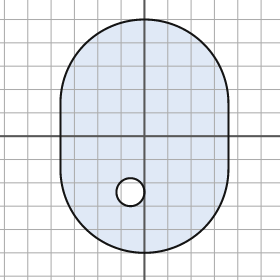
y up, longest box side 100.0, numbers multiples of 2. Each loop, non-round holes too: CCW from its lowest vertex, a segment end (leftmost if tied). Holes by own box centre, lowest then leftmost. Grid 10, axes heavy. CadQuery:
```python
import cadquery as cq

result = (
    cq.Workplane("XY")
    .moveTo(-36.0, -14.0)
    .threePointArc((0.0, -50.0), (36.0, -14.0))
    .lineTo(36.0, 14.0)
    .threePointArc((0.0, 50.0), (-36.0, 14.0))
    .close()
    .moveTo(-6.0, -24.0)
    .circle(6.0)
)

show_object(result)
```